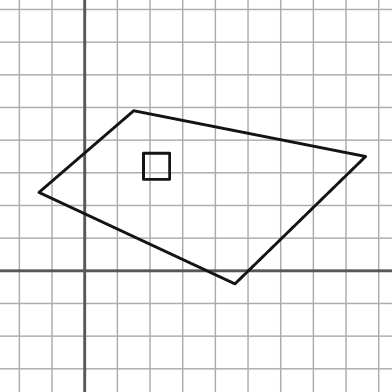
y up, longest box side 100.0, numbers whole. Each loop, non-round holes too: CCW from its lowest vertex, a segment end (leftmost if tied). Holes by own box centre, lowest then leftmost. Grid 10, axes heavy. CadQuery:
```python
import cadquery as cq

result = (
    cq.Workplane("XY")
    .moveTo(46.0, -4.0)
    .lineTo(86.0, 35.0)
    .lineTo(15.0, 49.0)
    .lineTo(-14.0, 24.0)
    .close()
    .moveTo(18.0, 28.0)
    .lineTo(26.0, 28.0)
    .lineTo(26.0, 36.0)
    .lineTo(18.0, 36.0)
    .close()
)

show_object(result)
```